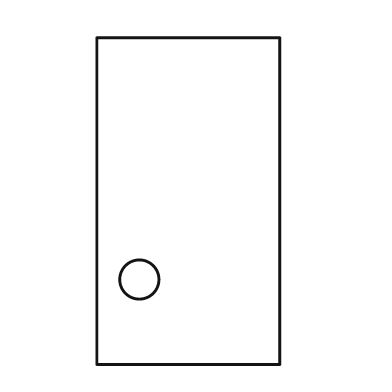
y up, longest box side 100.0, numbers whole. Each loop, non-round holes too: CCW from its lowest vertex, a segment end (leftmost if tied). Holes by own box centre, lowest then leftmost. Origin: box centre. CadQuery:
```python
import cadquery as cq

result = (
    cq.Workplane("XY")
    .moveTo(-28.0, -50.0)
    .lineTo(28.0, -50.0)
    .lineTo(28.0, 50.0)
    .lineTo(-28.0, 50.0)
    .close()
    .moveTo(-15.0, -24.0)
    .circle(6.0)
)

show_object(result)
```